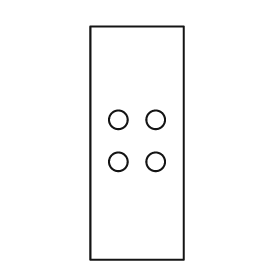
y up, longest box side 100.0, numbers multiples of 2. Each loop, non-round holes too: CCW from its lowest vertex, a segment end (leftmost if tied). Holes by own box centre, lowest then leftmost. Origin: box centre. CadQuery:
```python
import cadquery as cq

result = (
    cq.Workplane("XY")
    .moveTo(-20.0, -50.0)
    .lineTo(20.0, -50.0)
    .lineTo(20.0, 50.0)
    .lineTo(-20.0, 50.0)
    .close()
    .moveTo(-8.0, -8.0)
    .circle(4.0)
    .moveTo(8.0, -8.0)
    .circle(4.0)
    .moveTo(-8.0, 10.0)
    .circle(4.0)
    .moveTo(8.0, 10.0)
    .circle(4.0)
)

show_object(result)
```